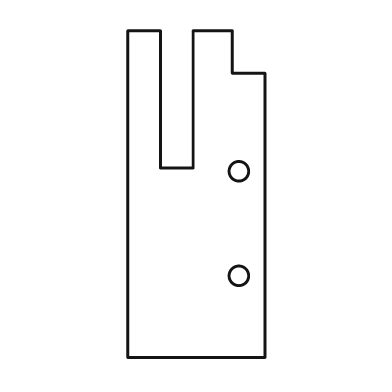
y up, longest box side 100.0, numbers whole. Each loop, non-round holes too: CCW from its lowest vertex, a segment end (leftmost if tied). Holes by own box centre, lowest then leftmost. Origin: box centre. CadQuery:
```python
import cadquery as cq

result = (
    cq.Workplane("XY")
    .moveTo(-21.0, -50.0)
    .lineTo(21.0, -50.0)
    .lineTo(21.0, 37.0)
    .lineTo(11.0, 37.0)
    .lineTo(11.0, 50.0)
    .lineTo(-1.0, 50.0)
    .lineTo(-1.0, 8.0)
    .lineTo(-11.0, 8.0)
    .lineTo(-11.0, 50.0)
    .lineTo(-21.0, 50.0)
    .close()
    .moveTo(13.0, -25.0)
    .circle(3.0)
    .moveTo(13.0, 7.0)
    .circle(3.0)
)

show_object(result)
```